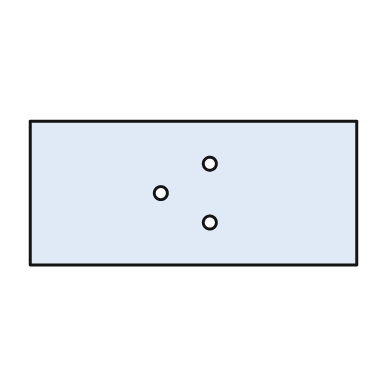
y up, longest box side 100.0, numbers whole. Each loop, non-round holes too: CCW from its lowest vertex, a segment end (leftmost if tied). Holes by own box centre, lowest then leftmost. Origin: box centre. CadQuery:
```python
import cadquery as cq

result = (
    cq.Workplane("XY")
    .moveTo(-50.0, -22.0)
    .lineTo(50.0, -22.0)
    .lineTo(50.0, 22.0)
    .lineTo(-50.0, 22.0)
    .close()
    .moveTo(5.0, -9.0)
    .circle(2.0)
    .moveTo(-10.0, 0.0)
    .circle(2.0)
    .moveTo(5.0, 9.0)
    .circle(2.0)
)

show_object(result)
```